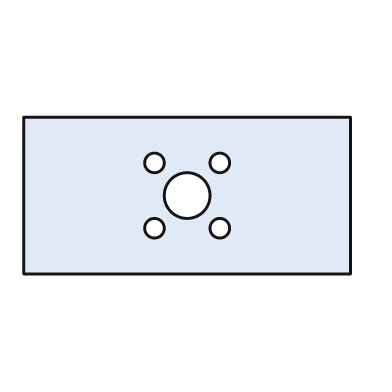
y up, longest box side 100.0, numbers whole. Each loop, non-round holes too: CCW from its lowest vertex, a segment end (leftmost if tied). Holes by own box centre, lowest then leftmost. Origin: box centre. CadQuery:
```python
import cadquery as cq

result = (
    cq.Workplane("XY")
    .moveTo(-50.0, -24.0)
    .lineTo(50.0, -24.0)
    .lineTo(50.0, 24.0)
    .lineTo(-50.0, 24.0)
    .close()
    .moveTo(-10.0, -10.0)
    .circle(3.0)
    .moveTo(10.0, -10.0)
    .circle(3.0)
    .moveTo(0.0, 0.0)
    .circle(7.0)
    .moveTo(-10.0, 10.0)
    .circle(3.0)
    .moveTo(10.0, 10.0)
    .circle(3.0)
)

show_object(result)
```